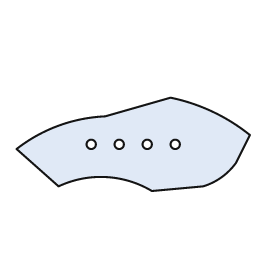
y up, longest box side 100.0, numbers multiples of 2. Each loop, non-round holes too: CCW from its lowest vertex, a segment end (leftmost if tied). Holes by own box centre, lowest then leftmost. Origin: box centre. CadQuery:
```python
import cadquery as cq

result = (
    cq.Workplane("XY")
    .moveTo(8.0, -20.0)
    .lineTo(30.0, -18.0)
    .threePointArc((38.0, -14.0), (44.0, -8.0))
    .lineTo(50.0, 4.0)
    .threePointArc((34.0, 14.0), (16.0, 20.0))
    .lineTo(-12.0, 12.0)
    .threePointArc((-32.0, 8.0), (-50.0, -2.0))
    .lineTo(-32.0, -18.0)
    .threePointArc((-12.0, -14.0), (8.0, -20.0))
    .close()
    .moveTo(-18.0, 0.0)
    .circle(2.0)
    .moveTo(-6.0, 0.0)
    .circle(2.0)
    .moveTo(6.0, 0.0)
    .circle(2.0)
    .moveTo(18.0, 0.0)
    .circle(2.0)
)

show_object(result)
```